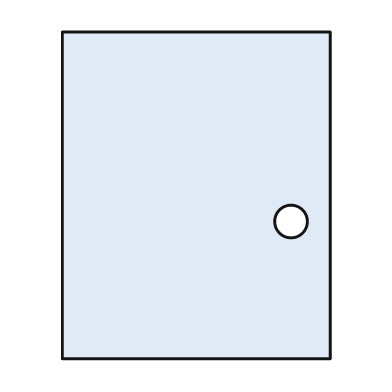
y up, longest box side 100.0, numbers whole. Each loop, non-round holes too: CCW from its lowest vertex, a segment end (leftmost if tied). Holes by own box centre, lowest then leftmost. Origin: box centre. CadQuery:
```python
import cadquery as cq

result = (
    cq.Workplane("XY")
    .moveTo(-41.0, -50.0)
    .lineTo(41.0, -50.0)
    .lineTo(41.0, 50.0)
    .lineTo(-41.0, 50.0)
    .close()
    .moveTo(29.0, -8.0)
    .circle(5.0)
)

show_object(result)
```